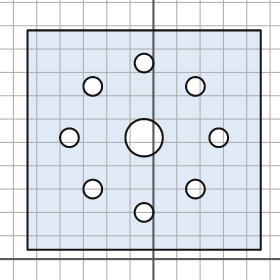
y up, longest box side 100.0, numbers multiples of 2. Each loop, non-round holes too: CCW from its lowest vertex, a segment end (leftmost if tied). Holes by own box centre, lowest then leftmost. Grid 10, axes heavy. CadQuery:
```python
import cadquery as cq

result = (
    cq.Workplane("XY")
    .moveTo(-54.0, 4.0)
    .lineTo(46.0, 4.0)
    .lineTo(46.0, 98.0)
    .lineTo(-54.0, 98.0)
    .close()
    .moveTo(-4.0, 20.0)
    .circle(4.0)
    .moveTo(-26.0, 30.0)
    .circle(4.0)
    .moveTo(18.0, 30.0)
    .circle(4.0)
    .moveTo(-36.0, 52.0)
    .circle(4.0)
    .moveTo(-4.0, 52.0)
    .circle(8.0)
    .moveTo(28.0, 52.0)
    .circle(4.0)
    .moveTo(-26.0, 74.0)
    .circle(4.0)
    .moveTo(18.0, 74.0)
    .circle(4.0)
    .moveTo(-4.0, 84.0)
    .circle(4.0)
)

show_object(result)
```